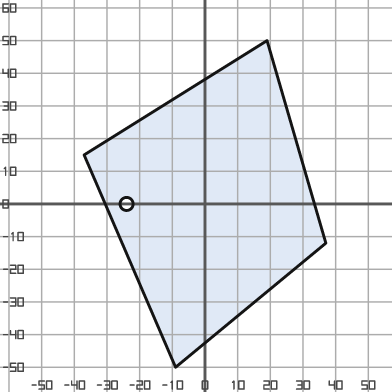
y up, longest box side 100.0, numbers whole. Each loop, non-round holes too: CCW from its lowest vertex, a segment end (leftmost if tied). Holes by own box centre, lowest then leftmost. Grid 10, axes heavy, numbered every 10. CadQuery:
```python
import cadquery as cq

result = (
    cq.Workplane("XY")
    .moveTo(-9.0, -50.0)
    .lineTo(37.0, -12.0)
    .lineTo(19.0, 50.0)
    .lineTo(-37.0, 15.0)
    .close()
    .moveTo(-24.0, 0.0)
    .circle(2.0)
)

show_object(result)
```